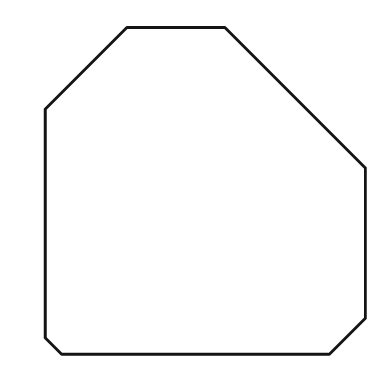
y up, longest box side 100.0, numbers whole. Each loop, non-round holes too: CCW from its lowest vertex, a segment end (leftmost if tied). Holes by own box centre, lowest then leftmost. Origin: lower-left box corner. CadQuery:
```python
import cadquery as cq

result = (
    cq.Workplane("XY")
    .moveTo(5.0, 0.0)
    .lineTo(87.0, 0.0)
    .lineTo(98.0, 11.0)
    .lineTo(98.0, 57.0)
    .lineTo(55.0, 100.0)
    .lineTo(25.0, 100.0)
    .lineTo(0.0, 75.0)
    .lineTo(0.0, 5.0)
    .close()
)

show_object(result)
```